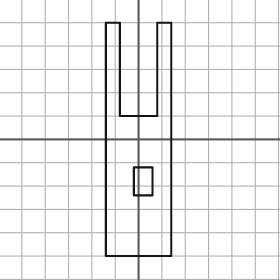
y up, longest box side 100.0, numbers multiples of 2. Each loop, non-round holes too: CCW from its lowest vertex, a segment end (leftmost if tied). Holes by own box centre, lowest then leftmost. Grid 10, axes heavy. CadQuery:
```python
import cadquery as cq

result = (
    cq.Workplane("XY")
    .moveTo(-14.0, -50.0)
    .lineTo(14.0, -50.0)
    .lineTo(14.0, 50.0)
    .lineTo(8.0, 50.0)
    .lineTo(8.0, 10.0)
    .lineTo(-8.0, 10.0)
    .lineTo(-8.0, 50.0)
    .lineTo(-14.0, 50.0)
    .close()
    .moveTo(-2.0, -24.0)
    .lineTo(6.0, -24.0)
    .lineTo(6.0, -12.0)
    .lineTo(-2.0, -12.0)
    .close()
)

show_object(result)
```